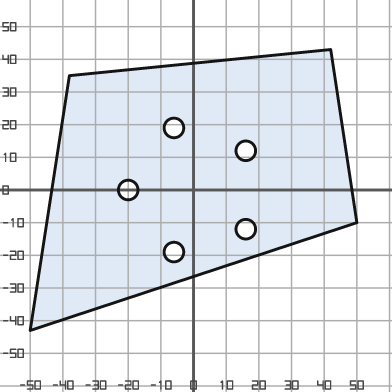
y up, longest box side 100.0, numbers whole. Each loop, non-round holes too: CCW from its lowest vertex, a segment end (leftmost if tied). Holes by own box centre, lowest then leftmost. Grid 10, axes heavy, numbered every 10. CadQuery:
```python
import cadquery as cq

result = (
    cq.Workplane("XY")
    .moveTo(-50.0, -43.0)
    .lineTo(50.0, -10.0)
    .lineTo(42.0, 43.0)
    .lineTo(-38.0, 35.0)
    .close()
    .moveTo(-6.0, -19.0)
    .circle(3.0)
    .moveTo(16.0, -12.0)
    .circle(3.0)
    .moveTo(-20.0, 0.0)
    .circle(3.0)
    .moveTo(16.0, 12.0)
    .circle(3.0)
    .moveTo(-6.0, 19.0)
    .circle(3.0)
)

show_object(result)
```